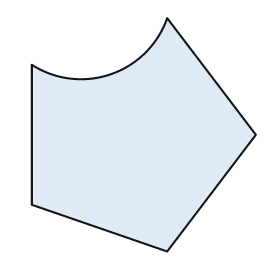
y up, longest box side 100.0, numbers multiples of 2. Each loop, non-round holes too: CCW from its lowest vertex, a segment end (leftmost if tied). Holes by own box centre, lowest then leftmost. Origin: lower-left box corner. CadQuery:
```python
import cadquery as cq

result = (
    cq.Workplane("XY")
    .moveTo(58.0, 0.0)
    .lineTo(96.0, 50.0)
    .lineTo(58.0, 100.0)
    .threePointArc((34.0, 76.0), (0.0, 80.0))
    .lineTo(0.0, 20.0)
    .close()
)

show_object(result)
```